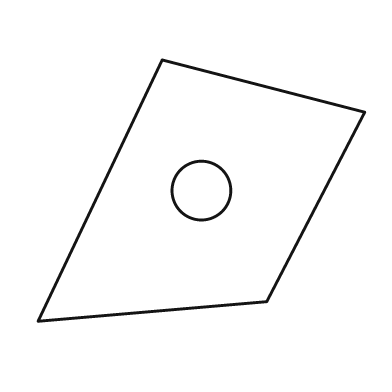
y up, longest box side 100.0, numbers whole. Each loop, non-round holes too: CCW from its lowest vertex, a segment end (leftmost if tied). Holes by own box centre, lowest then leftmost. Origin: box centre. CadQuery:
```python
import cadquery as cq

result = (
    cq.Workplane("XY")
    .moveTo(-50.0, -40.0)
    .lineTo(20.0, -34.0)
    .lineTo(50.0, 24.0)
    .lineTo(-12.0, 40.0)
    .close()
    .moveTo(0.0, 0.0)
    .circle(9.0)
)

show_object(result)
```